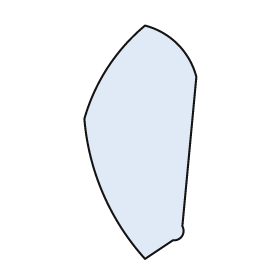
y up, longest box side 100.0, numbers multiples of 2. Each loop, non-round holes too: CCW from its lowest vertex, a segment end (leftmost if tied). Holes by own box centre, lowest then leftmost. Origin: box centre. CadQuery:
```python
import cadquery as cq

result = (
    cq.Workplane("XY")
    .moveTo(2.0, -50.0)
    .lineTo(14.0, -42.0)
    .threePointArc((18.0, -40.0), (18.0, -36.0))
    .lineTo(24.0, 28.0)
    .threePointArc((16.0, 42.0), (2.0, 50.0))
    .threePointArc((-14.0, 32.0), (-24.0, 10.0))
    .threePointArc((-16.0, -22.0), (2.0, -50.0))
    .close()
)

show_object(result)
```